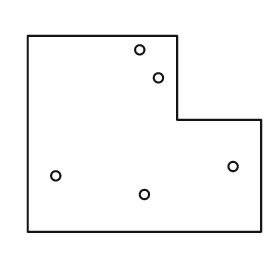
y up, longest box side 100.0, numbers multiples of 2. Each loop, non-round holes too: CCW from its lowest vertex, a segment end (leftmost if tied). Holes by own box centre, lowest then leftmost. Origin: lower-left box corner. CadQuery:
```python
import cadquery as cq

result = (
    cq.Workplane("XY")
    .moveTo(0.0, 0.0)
    .lineTo(100.0, 0.0)
    .lineTo(100.0, 48.0)
    .lineTo(64.0, 48.0)
    .lineTo(64.0, 84.0)
    .lineTo(0.0, 84.0)
    .close()
    .moveTo(50.0, 16.0)
    .circle(2.0)
    .moveTo(12.0, 24.0)
    .circle(2.0)
    .moveTo(88.0, 28.0)
    .circle(2.0)
    .moveTo(56.0, 66.0)
    .circle(2.0)
    .moveTo(48.0, 78.0)
    .circle(2.0)
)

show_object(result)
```